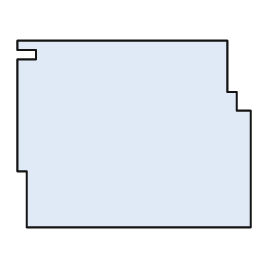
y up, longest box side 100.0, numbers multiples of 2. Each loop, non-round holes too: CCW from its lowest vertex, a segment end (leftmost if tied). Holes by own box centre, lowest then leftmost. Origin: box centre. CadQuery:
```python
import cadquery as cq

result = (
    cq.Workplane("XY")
    .moveTo(-46.0, -40.0)
    .lineTo(50.0, -40.0)
    .lineTo(50.0, 10.0)
    .lineTo(44.0, 10.0)
    .lineTo(44.0, 18.0)
    .lineTo(40.0, 18.0)
    .lineTo(40.0, 40.0)
    .lineTo(-50.0, 40.0)
    .lineTo(-50.0, 36.0)
    .lineTo(-42.0, 36.0)
    .lineTo(-42.0, 32.0)
    .lineTo(-50.0, 32.0)
    .lineTo(-50.0, -16.0)
    .lineTo(-46.0, -16.0)
    .close()
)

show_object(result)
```